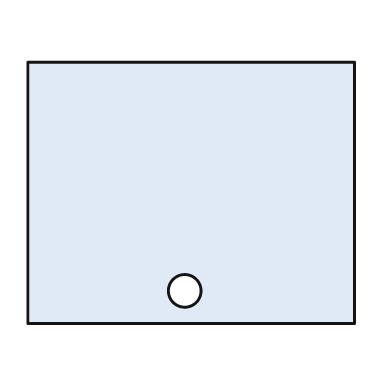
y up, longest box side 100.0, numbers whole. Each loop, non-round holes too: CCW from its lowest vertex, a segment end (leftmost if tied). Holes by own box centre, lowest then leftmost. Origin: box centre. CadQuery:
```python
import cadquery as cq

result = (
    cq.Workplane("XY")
    .moveTo(-50.0, -40.0)
    .lineTo(50.0, -40.0)
    .lineTo(50.0, 40.0)
    .lineTo(-50.0, 40.0)
    .close()
    .moveTo(-2.0, -30.0)
    .circle(5.0)
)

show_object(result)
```